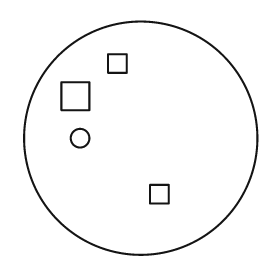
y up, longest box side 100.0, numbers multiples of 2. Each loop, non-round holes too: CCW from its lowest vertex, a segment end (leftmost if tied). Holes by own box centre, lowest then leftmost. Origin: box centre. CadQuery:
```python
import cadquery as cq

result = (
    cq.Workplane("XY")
    .moveTo(0.0, 0.0)
    .circle(50.0)
    .moveTo(4.0, -28.0)
    .lineTo(12.0, -28.0)
    .lineTo(12.0, -20.0)
    .lineTo(4.0, -20.0)
    .close()
    .moveTo(-26.0, 0.0)
    .circle(4.0)
    .moveTo(-34.0, 12.0)
    .lineTo(-22.0, 12.0)
    .lineTo(-22.0, 24.0)
    .lineTo(-34.0, 24.0)
    .close()
    .moveTo(-14.0, 28.0)
    .lineTo(-6.0, 28.0)
    .lineTo(-6.0, 36.0)
    .lineTo(-14.0, 36.0)
    .close()
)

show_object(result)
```